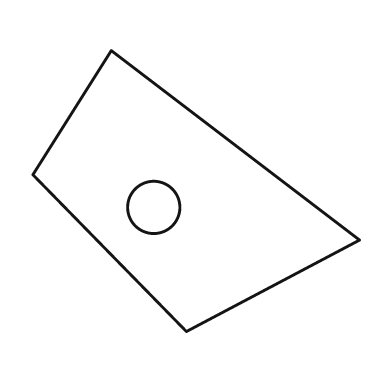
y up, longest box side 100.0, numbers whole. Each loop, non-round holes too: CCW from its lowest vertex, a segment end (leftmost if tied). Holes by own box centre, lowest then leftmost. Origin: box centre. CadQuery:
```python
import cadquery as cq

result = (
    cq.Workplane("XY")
    .moveTo(-3.0, -43.0)
    .lineTo(50.0, -15.0)
    .lineTo(-26.0, 43.0)
    .lineTo(-50.0, 5.0)
    .close()
    .moveTo(-13.0, -5.0)
    .circle(8.0)
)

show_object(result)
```